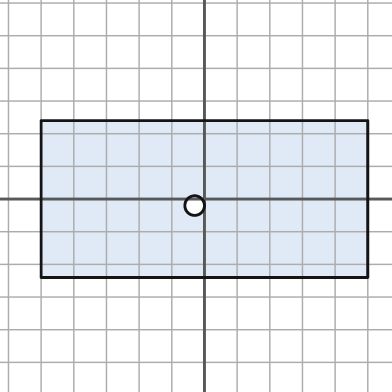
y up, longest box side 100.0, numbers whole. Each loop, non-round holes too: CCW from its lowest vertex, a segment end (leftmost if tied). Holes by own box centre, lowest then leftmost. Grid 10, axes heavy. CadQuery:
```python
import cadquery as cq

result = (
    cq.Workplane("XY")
    .moveTo(-50.0, -24.0)
    .lineTo(50.0, -24.0)
    .lineTo(50.0, 24.0)
    .lineTo(-50.0, 24.0)
    .close()
    .moveTo(-3.0, -2.0)
    .circle(3.0)
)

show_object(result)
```